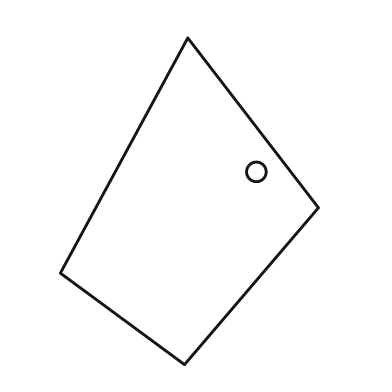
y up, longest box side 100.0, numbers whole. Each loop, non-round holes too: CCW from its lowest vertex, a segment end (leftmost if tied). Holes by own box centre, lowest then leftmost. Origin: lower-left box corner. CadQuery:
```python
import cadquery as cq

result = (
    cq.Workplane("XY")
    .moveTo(38.0, 0.0)
    .lineTo(79.0, 48.0)
    .lineTo(39.0, 100.0)
    .lineTo(0.0, 28.0)
    .close()
    .moveTo(60.0, 59.0)
    .circle(3.0)
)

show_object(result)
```